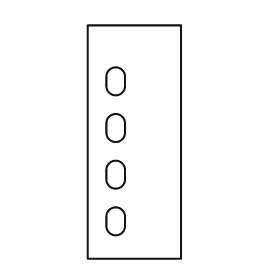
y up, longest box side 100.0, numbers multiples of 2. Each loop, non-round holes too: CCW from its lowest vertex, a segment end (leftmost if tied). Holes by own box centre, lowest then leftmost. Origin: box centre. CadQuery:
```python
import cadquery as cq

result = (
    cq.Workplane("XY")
    .moveTo(-20.0, -50.0)
    .lineTo(20.0, -50.0)
    .lineTo(20.0, 50.0)
    .lineTo(-20.0, 50.0)
    .close()
    .moveTo(-12.0, -36.0)
    .threePointArc((-8.0, -40.0), (-4.0, -36.0))
    .lineTo(-4.0, -32.0)
    .threePointArc((-8.0, -28.0), (-12.0, -32.0))
    .close()
    .moveTo(-12.0, -16.0)
    .threePointArc((-8.0, -20.0), (-4.0, -16.0))
    .lineTo(-4.0, -12.0)
    .threePointArc((-8.0, -8.0), (-12.0, -12.0))
    .close()
    .moveTo(-12.0, 4.0)
    .threePointArc((-8.0, 0.0), (-4.0, 4.0))
    .lineTo(-4.0, 8.0)
    .threePointArc((-8.0, 12.0), (-12.0, 8.0))
    .close()
    .moveTo(-12.0, 24.0)
    .threePointArc((-8.0, 20.0), (-4.0, 24.0))
    .lineTo(-4.0, 28.0)
    .threePointArc((-8.0, 32.0), (-12.0, 28.0))
    .close()
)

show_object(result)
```